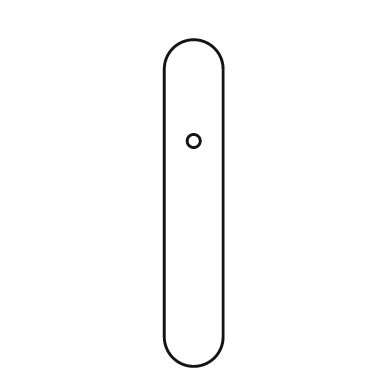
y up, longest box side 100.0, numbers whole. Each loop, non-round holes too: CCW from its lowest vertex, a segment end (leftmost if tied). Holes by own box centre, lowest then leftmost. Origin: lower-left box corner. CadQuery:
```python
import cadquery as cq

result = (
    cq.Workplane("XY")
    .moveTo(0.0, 9.0)
    .threePointArc((9.0, 0.0), (18.0, 9.0))
    .lineTo(18.0, 91.0)
    .threePointArc((9.0, 100.0), (0.0, 91.0))
    .close()
    .moveTo(9.0, 69.0)
    .circle(2.0)
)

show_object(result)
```